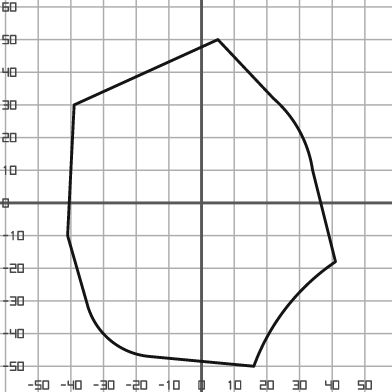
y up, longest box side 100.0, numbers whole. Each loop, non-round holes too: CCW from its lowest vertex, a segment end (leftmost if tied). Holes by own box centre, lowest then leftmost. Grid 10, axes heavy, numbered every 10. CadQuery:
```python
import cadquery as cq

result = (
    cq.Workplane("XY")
    .moveTo(16.0, -50.0)
    .threePointArc((26.0, -32.0), (41.0, -18.0))
    .lineTo(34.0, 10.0)
    .threePointArc((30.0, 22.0), (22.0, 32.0))
    .lineTo(5.0, 50.0)
    .lineTo(-39.0, 30.0)
    .lineTo(-41.0, -10.0)
    .lineTo(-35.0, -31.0)
    .threePointArc((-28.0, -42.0), (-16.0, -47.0))
    .close()
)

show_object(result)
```